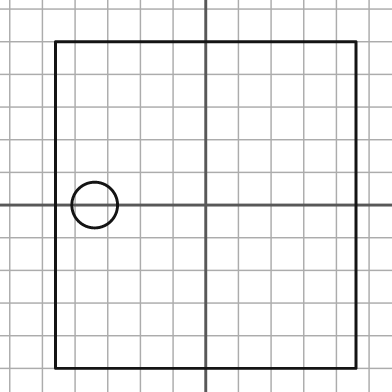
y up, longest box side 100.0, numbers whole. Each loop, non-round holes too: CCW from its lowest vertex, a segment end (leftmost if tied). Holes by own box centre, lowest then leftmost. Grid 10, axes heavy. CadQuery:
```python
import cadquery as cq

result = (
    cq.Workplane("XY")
    .moveTo(-46.0, -50.0)
    .lineTo(46.0, -50.0)
    .lineTo(46.0, 50.0)
    .lineTo(-46.0, 50.0)
    .close()
    .moveTo(-34.0, 0.0)
    .circle(7.0)
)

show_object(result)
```